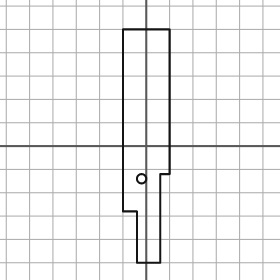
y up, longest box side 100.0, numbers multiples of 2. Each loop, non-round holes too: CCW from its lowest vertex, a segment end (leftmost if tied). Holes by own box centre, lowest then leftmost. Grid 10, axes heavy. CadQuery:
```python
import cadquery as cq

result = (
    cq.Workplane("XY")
    .moveTo(-4.0, -50.0)
    .lineTo(6.0, -50.0)
    .lineTo(6.0, -12.0)
    .lineTo(10.0, -12.0)
    .lineTo(10.0, 50.0)
    .lineTo(-10.0, 50.0)
    .lineTo(-10.0, -28.0)
    .lineTo(-4.0, -28.0)
    .close()
    .moveTo(-2.0, -14.0)
    .circle(2.0)
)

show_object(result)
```